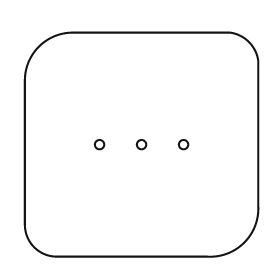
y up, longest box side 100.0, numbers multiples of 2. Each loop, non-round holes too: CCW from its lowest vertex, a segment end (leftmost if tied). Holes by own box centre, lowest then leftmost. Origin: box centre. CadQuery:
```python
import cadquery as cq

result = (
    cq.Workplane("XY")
    .moveTo(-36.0, -48.0)
    .lineTo(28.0, -48.0)
    .threePointArc((44.0, -42.0), (50.0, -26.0))
    .lineTo(50.0, 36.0)
    .threePointArc((46.0, 44.0), (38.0, 48.0))
    .lineTo(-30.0, 48.0)
    .threePointArc((-44.0, 42.0), (-50.0, 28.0))
    .lineTo(-50.0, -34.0)
    .threePointArc((-46.0, -44.0), (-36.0, -48.0))
    .close()
    .moveTo(-18.0, 0.0)
    .circle(2.0)
    .moveTo(0.0, 0.0)
    .circle(2.0)
    .moveTo(18.0, 0.0)
    .circle(2.0)
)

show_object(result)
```